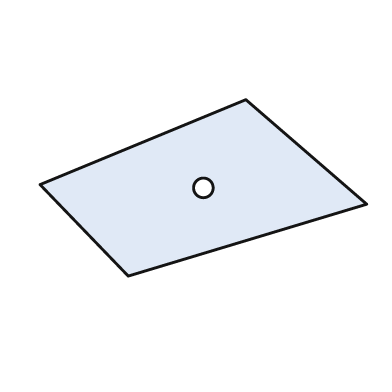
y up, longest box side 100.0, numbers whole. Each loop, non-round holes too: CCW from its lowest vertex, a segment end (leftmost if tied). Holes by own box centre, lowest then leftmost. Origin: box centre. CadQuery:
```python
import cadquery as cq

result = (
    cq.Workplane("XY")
    .moveTo(-23.0, -27.0)
    .lineTo(50.0, -5.0)
    .lineTo(13.0, 27.0)
    .lineTo(-50.0, 1.0)
    .close()
    .moveTo(0.0, 0.0)
    .circle(3.0)
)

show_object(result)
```